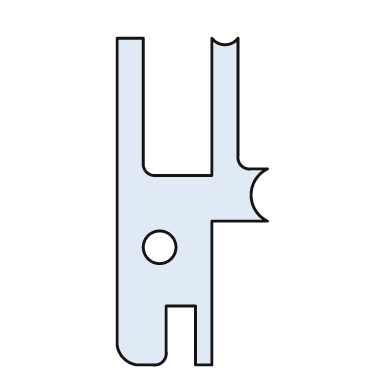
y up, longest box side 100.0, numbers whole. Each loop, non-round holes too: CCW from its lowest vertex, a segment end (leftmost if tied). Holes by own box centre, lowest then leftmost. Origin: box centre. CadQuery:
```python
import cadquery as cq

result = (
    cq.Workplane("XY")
    .moveTo(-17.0, -50.0)
    .lineTo(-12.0, -50.0)
    .threePointArc((-9.0, -49.0), (-8.0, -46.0))
    .lineTo(-8.0, -32.0)
    .lineTo(1.0, -32.0)
    .lineTo(1.0, -50.0)
    .lineTo(6.0, -50.0)
    .lineTo(6.0, -6.0)
    .lineTo(23.0, -6.0)
    .threePointArc((18.0, 2.0), (23.0, 10.0))
    .lineTo(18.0, 10.0)
    .threePointArc((15.0, 11.0), (14.0, 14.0))
    .lineTo(14.0, 50.0)
    .threePointArc((10.0, 48.0), (6.0, 50.0))
    .lineTo(6.0, 8.0)
    .lineTo(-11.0, 8.0)
    .threePointArc((-14.0, 9.0), (-15.0, 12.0))
    .lineTo(-15.0, 50.0)
    .lineTo(-23.0, 50.0)
    .lineTo(-23.0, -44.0)
    .threePointArc((-21.0, -48.0), (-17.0, -50.0))
    .close()
    .moveTo(-10.0, -14.0)
    .circle(5.0)
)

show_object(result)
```